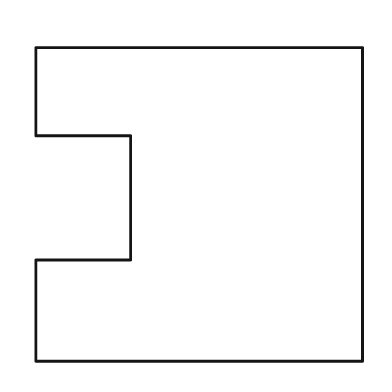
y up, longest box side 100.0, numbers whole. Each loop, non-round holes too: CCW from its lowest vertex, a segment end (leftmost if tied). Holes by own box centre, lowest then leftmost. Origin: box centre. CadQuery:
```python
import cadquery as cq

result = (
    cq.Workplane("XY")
    .moveTo(-50.0, -48.0)
    .lineTo(50.0, -48.0)
    .lineTo(50.0, 48.0)
    .lineTo(-50.0, 48.0)
    .lineTo(-50.0, 21.0)
    .lineTo(-21.0, 21.0)
    .lineTo(-21.0, -17.0)
    .lineTo(-50.0, -17.0)
    .close()
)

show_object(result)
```